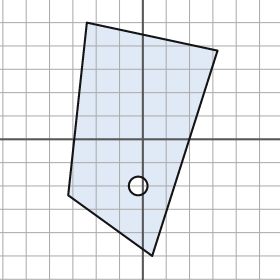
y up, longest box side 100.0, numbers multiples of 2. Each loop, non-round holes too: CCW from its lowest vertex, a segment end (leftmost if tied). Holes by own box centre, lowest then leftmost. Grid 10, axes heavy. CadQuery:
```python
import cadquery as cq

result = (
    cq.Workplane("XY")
    .moveTo(4.0, -50.0)
    .lineTo(32.0, 38.0)
    .lineTo(-24.0, 50.0)
    .lineTo(-32.0, -24.0)
    .close()
    .moveTo(-2.0, -20.0)
    .circle(4.0)
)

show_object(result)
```